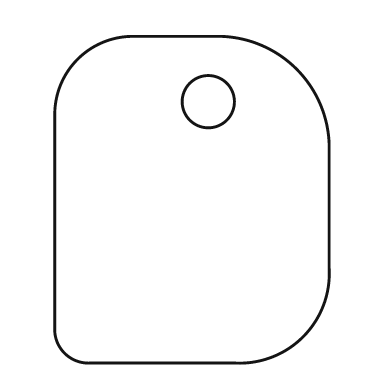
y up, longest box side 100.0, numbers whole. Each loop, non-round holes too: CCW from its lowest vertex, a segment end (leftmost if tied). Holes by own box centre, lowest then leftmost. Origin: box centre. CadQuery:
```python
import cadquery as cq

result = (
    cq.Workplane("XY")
    .moveTo(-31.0, -50.0)
    .lineTo(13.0, -50.0)
    .threePointArc((34.0, -42.0), (42.0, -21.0))
    .lineTo(42.0, 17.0)
    .threePointArc((32.0, 40.0), (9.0, 50.0))
    .lineTo(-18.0, 50.0)
    .threePointArc((-35.0, 43.0), (-42.0, 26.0))
    .lineTo(-42.0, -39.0)
    .threePointArc((-39.0, -47.0), (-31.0, -50.0))
    .close()
    .moveTo(5.0, 30.0)
    .circle(8.0)
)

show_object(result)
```